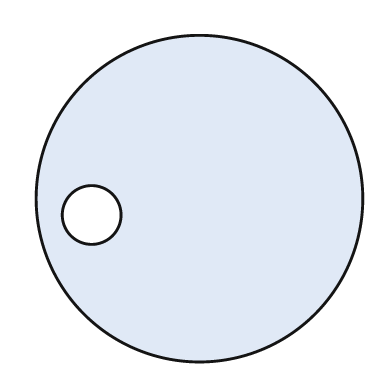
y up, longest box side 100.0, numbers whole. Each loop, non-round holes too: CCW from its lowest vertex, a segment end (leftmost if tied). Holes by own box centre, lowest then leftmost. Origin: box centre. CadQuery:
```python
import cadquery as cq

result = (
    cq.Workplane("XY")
    .moveTo(0.0, 0.0)
    .circle(50.0)
    .moveTo(-33.0, -5.0)
    .circle(9.0)
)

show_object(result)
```